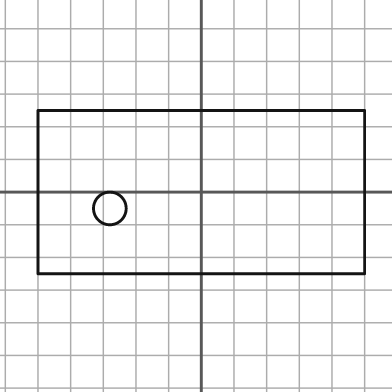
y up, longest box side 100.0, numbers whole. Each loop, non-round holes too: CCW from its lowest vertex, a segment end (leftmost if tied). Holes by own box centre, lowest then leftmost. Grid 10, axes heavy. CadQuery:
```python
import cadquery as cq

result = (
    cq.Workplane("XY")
    .moveTo(-50.0, -25.0)
    .lineTo(50.0, -25.0)
    .lineTo(50.0, 25.0)
    .lineTo(-50.0, 25.0)
    .close()
    .moveTo(-28.0, -5.0)
    .circle(5.0)
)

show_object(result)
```